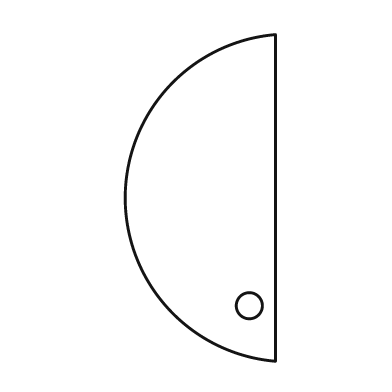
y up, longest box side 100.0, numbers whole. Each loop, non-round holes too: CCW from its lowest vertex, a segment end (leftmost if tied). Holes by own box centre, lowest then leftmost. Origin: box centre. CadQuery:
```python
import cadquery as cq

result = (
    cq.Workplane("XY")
    .moveTo(23.0, -50.0)
    .lineTo(23.0, 50.0)
    .threePointArc((-23.0, 0.0), (23.0, -50.0))
    .close()
    .moveTo(15.0, -33.0)
    .circle(4.0)
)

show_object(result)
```